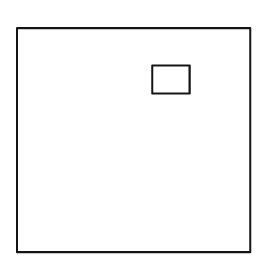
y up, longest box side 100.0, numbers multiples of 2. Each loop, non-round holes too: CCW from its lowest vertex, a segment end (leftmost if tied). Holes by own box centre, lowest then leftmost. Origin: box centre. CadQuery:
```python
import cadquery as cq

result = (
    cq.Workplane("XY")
    .moveTo(-50.0, -48.0)
    .lineTo(50.0, -48.0)
    .lineTo(50.0, 48.0)
    .lineTo(-50.0, 48.0)
    .close()
    .moveTo(8.0, 20.0)
    .lineTo(24.0, 20.0)
    .lineTo(24.0, 32.0)
    .lineTo(8.0, 32.0)
    .close()
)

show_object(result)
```